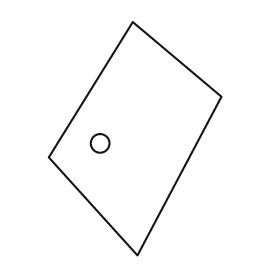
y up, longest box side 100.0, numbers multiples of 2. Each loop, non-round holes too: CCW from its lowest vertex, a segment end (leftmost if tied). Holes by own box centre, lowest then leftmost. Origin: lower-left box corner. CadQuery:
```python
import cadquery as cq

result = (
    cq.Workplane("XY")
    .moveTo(38.0, 0.0)
    .lineTo(74.0, 68.0)
    .lineTo(36.0, 100.0)
    .lineTo(0.0, 42.0)
    .close()
    .moveTo(22.0, 48.0)
    .circle(4.0)
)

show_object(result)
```